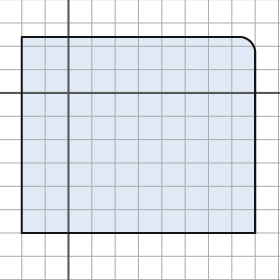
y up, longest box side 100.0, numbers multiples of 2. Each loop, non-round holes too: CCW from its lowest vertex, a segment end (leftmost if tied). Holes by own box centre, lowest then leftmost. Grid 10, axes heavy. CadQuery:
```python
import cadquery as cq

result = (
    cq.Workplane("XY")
    .moveTo(-20.0, -60.0)
    .lineTo(80.0, -60.0)
    .lineTo(80.0, 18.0)
    .threePointArc((78.0, 22.0), (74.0, 24.0))
    .lineTo(-20.0, 24.0)
    .close()
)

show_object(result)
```